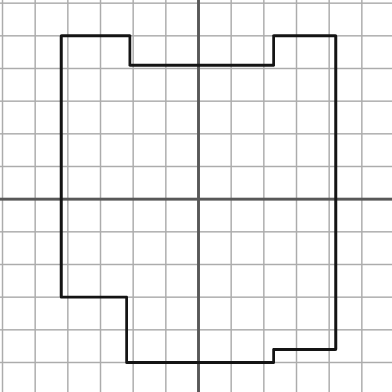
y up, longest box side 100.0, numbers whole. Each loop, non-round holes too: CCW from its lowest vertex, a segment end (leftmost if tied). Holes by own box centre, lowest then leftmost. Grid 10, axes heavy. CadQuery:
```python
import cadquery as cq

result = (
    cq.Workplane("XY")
    .moveTo(-22.0, -50.0)
    .lineTo(23.0, -50.0)
    .lineTo(23.0, -46.0)
    .lineTo(42.0, -46.0)
    .lineTo(42.0, 50.0)
    .lineTo(23.0, 50.0)
    .lineTo(23.0, 41.0)
    .lineTo(-21.0, 41.0)
    .lineTo(-21.0, 50.0)
    .lineTo(-42.0, 50.0)
    .lineTo(-42.0, -30.0)
    .lineTo(-22.0, -30.0)
    .close()
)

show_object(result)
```